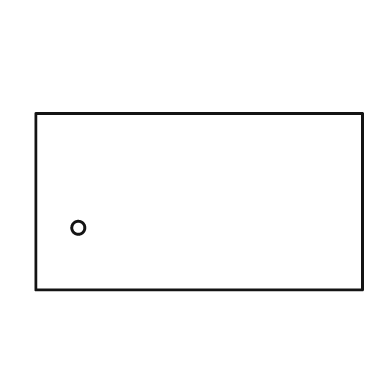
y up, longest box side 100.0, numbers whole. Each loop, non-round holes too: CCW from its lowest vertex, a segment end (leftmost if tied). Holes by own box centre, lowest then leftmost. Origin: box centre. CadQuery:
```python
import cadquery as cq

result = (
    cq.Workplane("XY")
    .moveTo(-50.0, -27.0)
    .lineTo(50.0, -27.0)
    .lineTo(50.0, 27.0)
    .lineTo(-50.0, 27.0)
    .close()
    .moveTo(-37.0, -8.0)
    .circle(2.0)
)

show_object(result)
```